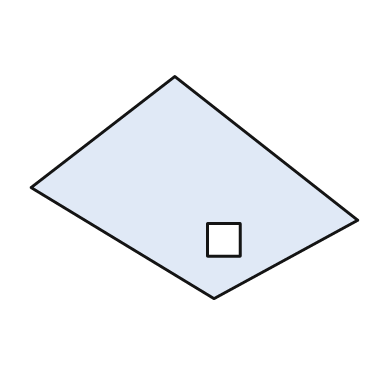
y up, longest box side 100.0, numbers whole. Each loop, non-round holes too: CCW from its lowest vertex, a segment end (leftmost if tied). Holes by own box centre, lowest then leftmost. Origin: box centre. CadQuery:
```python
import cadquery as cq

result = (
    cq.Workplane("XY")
    .moveTo(6.0, -34.0)
    .lineTo(50.0, -10.0)
    .lineTo(-6.0, 34.0)
    .lineTo(-50.0, 0.0)
    .close()
    .moveTo(4.0, -21.0)
    .lineTo(14.0, -21.0)
    .lineTo(14.0, -11.0)
    .lineTo(4.0, -11.0)
    .close()
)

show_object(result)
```